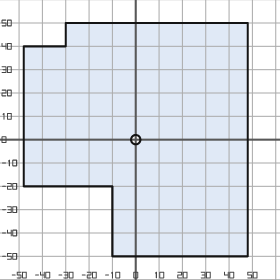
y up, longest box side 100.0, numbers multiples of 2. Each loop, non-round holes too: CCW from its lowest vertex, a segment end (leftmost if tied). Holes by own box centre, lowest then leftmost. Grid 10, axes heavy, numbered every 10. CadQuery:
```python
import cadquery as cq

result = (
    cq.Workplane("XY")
    .moveTo(-10.0, -50.0)
    .lineTo(48.0, -50.0)
    .lineTo(48.0, 50.0)
    .lineTo(-30.0, 50.0)
    .lineTo(-30.0, 40.0)
    .lineTo(-48.0, 40.0)
    .lineTo(-48.0, -20.0)
    .lineTo(-10.0, -20.0)
    .close()
    .moveTo(0.0, 0.0)
    .circle(2.0)
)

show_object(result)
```